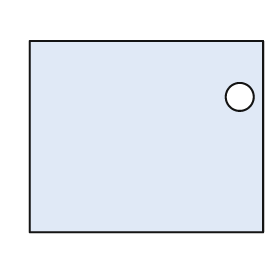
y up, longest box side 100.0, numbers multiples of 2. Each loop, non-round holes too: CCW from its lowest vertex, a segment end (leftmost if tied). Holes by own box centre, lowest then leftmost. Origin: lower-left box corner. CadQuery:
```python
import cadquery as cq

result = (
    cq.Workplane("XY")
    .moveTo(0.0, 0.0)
    .lineTo(100.0, 0.0)
    .lineTo(100.0, 82.0)
    .lineTo(0.0, 82.0)
    .close()
    .moveTo(90.0, 58.0)
    .circle(6.0)
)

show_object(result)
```